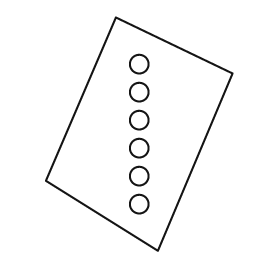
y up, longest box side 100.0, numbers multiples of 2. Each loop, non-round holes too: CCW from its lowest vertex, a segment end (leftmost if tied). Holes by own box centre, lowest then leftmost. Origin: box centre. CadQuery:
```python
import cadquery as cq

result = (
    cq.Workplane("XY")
    .moveTo(8.0, -50.0)
    .lineTo(40.0, 26.0)
    .lineTo(-10.0, 50.0)
    .lineTo(-40.0, -20.0)
    .close()
    .moveTo(0.0, -30.0)
    .circle(4.0)
    .moveTo(0.0, -18.0)
    .circle(4.0)
    .moveTo(0.0, -6.0)
    .circle(4.0)
    .moveTo(0.0, 6.0)
    .circle(4.0)
    .moveTo(0.0, 18.0)
    .circle(4.0)
    .moveTo(0.0, 30.0)
    .circle(4.0)
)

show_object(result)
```